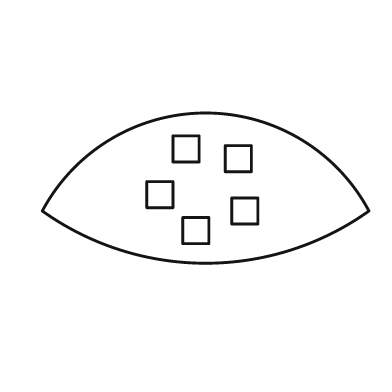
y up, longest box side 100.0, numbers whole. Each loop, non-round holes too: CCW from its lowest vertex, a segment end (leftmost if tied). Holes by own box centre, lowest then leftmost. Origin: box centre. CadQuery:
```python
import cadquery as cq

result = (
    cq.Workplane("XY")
    .moveTo(-50.0, -7.0)
    .threePointArc((0.0, -23.0), (50.0, -7.0))
    .threePointArc((0.0, 23.0), (-50.0, -7.0))
    .close()
    .moveTo(-7.0, -17.0)
    .lineTo(1.0, -17.0)
    .lineTo(1.0, -9.0)
    .lineTo(-7.0, -9.0)
    .close()
    .moveTo(8.0, -11.0)
    .lineTo(16.0, -11.0)
    .lineTo(16.0, -3.0)
    .lineTo(8.0, -3.0)
    .close()
    .moveTo(-18.0, -6.0)
    .lineTo(-10.0, -6.0)
    .lineTo(-10.0, 2.0)
    .lineTo(-18.0, 2.0)
    .close()
    .moveTo(6.0, 5.0)
    .lineTo(14.0, 5.0)
    .lineTo(14.0, 13.0)
    .lineTo(6.0, 13.0)
    .close()
    .moveTo(-10.0, 8.0)
    .lineTo(-2.0, 8.0)
    .lineTo(-2.0, 16.0)
    .lineTo(-10.0, 16.0)
    .close()
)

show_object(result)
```